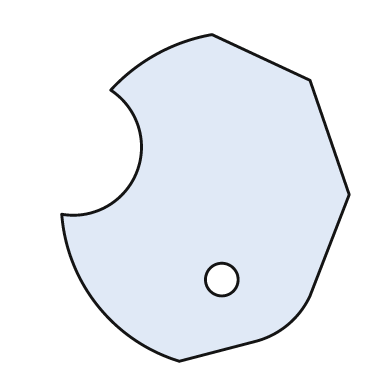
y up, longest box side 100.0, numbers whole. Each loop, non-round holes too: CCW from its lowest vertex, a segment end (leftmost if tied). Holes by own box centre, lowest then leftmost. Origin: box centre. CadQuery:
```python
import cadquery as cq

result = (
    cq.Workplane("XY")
    .moveTo(-8.0, -50.0)
    .lineTo(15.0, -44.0)
    .threePointArc((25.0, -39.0), (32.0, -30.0))
    .lineTo(44.0, 1.0)
    .lineTo(32.0, 36.0)
    .lineTo(2.0, 50.0)
    .threePointArc((-15.0, 44.0), (-29.0, 33.0))
    .threePointArc((-21.0, 8.0), (-44.0, -5.0))
    .threePointArc((-33.0, -33.0), (-8.0, -50.0))
    .close()
    .moveTo(5.0, -25.0)
    .circle(5.0)
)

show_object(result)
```